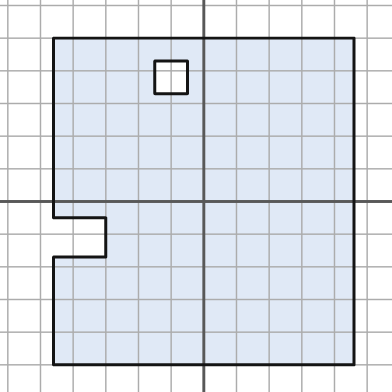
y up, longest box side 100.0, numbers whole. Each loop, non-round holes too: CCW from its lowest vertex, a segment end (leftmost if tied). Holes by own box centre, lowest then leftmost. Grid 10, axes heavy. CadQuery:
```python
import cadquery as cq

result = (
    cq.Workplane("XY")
    .moveTo(-46.0, -50.0)
    .lineTo(46.0, -50.0)
    .lineTo(46.0, 50.0)
    .lineTo(-46.0, 50.0)
    .lineTo(-46.0, -5.0)
    .lineTo(-30.0, -5.0)
    .lineTo(-30.0, -17.0)
    .lineTo(-46.0, -17.0)
    .close()
    .moveTo(-15.0, 33.0)
    .lineTo(-5.0, 33.0)
    .lineTo(-5.0, 43.0)
    .lineTo(-15.0, 43.0)
    .close()
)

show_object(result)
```